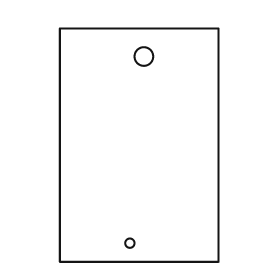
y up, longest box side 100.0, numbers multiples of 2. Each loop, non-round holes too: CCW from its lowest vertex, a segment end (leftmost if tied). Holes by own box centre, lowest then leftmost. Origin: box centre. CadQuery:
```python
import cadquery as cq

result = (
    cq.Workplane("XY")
    .moveTo(-34.0, -50.0)
    .lineTo(34.0, -50.0)
    .lineTo(34.0, 50.0)
    .lineTo(-34.0, 50.0)
    .close()
    .moveTo(-4.0, -42.0)
    .circle(2.0)
    .moveTo(2.0, 38.0)
    .circle(4.0)
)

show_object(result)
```